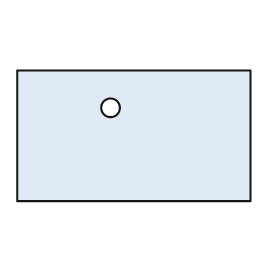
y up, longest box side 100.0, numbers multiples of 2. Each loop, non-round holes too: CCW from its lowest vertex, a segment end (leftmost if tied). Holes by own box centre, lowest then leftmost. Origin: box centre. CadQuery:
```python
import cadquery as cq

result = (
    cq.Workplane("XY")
    .moveTo(-50.0, -28.0)
    .lineTo(50.0, -28.0)
    .lineTo(50.0, 28.0)
    .lineTo(-50.0, 28.0)
    .close()
    .moveTo(-10.0, 12.0)
    .circle(4.0)
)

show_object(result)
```